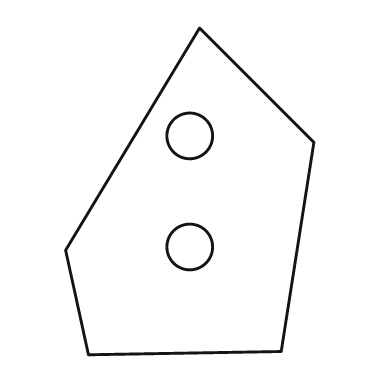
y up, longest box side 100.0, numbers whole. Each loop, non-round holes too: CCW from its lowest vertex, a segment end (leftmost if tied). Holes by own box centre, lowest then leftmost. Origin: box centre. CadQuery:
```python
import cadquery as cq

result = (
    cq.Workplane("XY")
    .moveTo(-31.0, -50.0)
    .lineTo(28.0, -49.0)
    .lineTo(38.0, 15.0)
    .lineTo(3.0, 50.0)
    .lineTo(-38.0, -18.0)
    .close()
    .moveTo(0.0, -17.0)
    .circle(7.0)
    .moveTo(0.0, 17.0)
    .circle(7.0)
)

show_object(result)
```